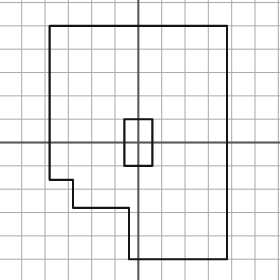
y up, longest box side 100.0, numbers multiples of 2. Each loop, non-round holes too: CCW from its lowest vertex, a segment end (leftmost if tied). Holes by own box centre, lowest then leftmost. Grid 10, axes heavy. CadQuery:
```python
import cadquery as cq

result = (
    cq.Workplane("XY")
    .moveTo(-4.0, -50.0)
    .lineTo(38.0, -50.0)
    .lineTo(38.0, 50.0)
    .lineTo(-38.0, 50.0)
    .lineTo(-38.0, -16.0)
    .lineTo(-28.0, -16.0)
    .lineTo(-28.0, -28.0)
    .lineTo(-4.0, -28.0)
    .close()
    .moveTo(-6.0, -10.0)
    .lineTo(6.0, -10.0)
    .lineTo(6.0, 10.0)
    .lineTo(-6.0, 10.0)
    .close()
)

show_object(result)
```